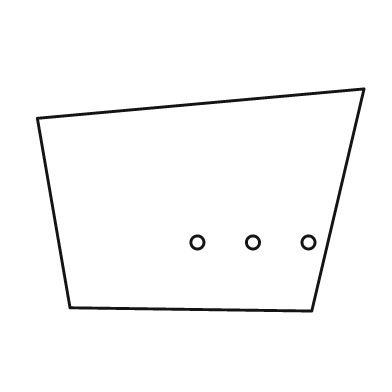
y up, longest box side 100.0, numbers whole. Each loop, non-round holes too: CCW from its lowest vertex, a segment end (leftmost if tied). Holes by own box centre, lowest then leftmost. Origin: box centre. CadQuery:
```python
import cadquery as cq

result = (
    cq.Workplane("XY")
    .moveTo(34.0, -34.0)
    .lineTo(50.0, 34.0)
    .lineTo(-50.0, 25.0)
    .lineTo(-40.0, -33.0)
    .close()
    .moveTo(-1.0, -13.0)
    .circle(2.0)
    .moveTo(16.0, -13.0)
    .circle(2.0)
    .moveTo(33.0, -13.0)
    .circle(2.0)
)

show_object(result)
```